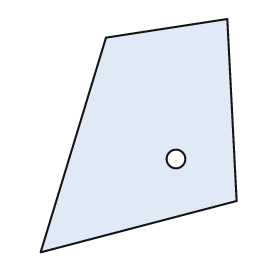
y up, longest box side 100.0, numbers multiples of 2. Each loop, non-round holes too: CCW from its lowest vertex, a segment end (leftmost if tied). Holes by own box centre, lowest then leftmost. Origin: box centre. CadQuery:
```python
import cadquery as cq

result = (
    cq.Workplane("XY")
    .moveTo(-42.0, -50.0)
    .lineTo(42.0, -28.0)
    .lineTo(38.0, 50.0)
    .lineTo(-14.0, 42.0)
    .close()
    .moveTo(16.0, -10.0)
    .circle(4.0)
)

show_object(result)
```